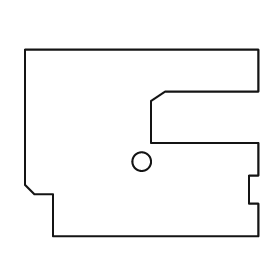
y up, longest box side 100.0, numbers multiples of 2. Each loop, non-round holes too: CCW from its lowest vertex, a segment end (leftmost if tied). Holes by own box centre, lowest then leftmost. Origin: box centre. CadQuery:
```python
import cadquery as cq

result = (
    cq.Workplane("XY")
    .moveTo(-38.0, -40.0)
    .lineTo(50.0, -40.0)
    .lineTo(50.0, -26.0)
    .lineTo(46.0, -26.0)
    .lineTo(46.0, -14.0)
    .lineTo(50.0, -14.0)
    .lineTo(50.0, 0.0)
    .lineTo(4.0, 0.0)
    .lineTo(4.0, 18.0)
    .lineTo(10.0, 22.0)
    .lineTo(50.0, 22.0)
    .lineTo(50.0, 40.0)
    .lineTo(-50.0, 40.0)
    .lineTo(-50.0, -18.0)
    .lineTo(-46.0, -22.0)
    .lineTo(-38.0, -22.0)
    .close()
    .moveTo(0.0, -8.0)
    .circle(4.0)
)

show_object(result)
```